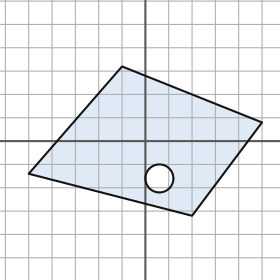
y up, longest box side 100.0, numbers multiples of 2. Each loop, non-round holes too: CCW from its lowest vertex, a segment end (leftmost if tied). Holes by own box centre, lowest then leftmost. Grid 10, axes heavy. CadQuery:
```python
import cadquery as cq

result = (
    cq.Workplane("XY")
    .moveTo(20.0, -32.0)
    .lineTo(50.0, 8.0)
    .lineTo(-10.0, 32.0)
    .lineTo(-50.0, -14.0)
    .close()
    .moveTo(6.0, -16.0)
    .circle(6.0)
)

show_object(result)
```